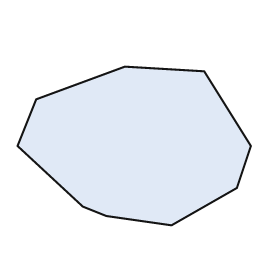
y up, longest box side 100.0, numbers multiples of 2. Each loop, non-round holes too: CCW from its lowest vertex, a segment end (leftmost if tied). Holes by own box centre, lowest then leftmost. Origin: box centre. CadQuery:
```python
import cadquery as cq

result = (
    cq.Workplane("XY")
    .moveTo(16.0, -34.0)
    .lineTo(44.0, -18.0)
    .lineTo(50.0, 0.0)
    .lineTo(30.0, 32.0)
    .lineTo(-4.0, 34.0)
    .lineTo(-42.0, 20.0)
    .lineTo(-50.0, 0.0)
    .lineTo(-22.0, -26.0)
    .lineTo(-12.0, -30.0)
    .close()
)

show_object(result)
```